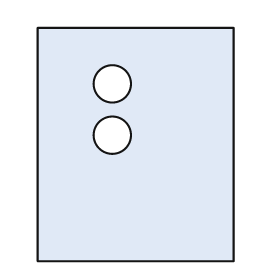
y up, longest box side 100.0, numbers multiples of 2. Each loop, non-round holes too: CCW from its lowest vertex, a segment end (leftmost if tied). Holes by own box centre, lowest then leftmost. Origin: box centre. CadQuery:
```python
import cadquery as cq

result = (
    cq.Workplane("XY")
    .moveTo(-42.0, -50.0)
    .lineTo(42.0, -50.0)
    .lineTo(42.0, 50.0)
    .lineTo(-42.0, 50.0)
    .close()
    .moveTo(-10.0, 4.0)
    .circle(8.0)
    .moveTo(-10.0, 26.0)
    .circle(8.0)
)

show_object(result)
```